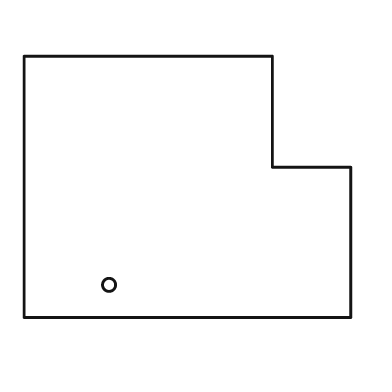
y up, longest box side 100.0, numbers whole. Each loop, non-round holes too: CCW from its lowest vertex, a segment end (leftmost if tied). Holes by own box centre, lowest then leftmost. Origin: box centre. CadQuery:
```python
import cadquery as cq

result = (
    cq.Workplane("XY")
    .moveTo(-50.0, -40.0)
    .lineTo(50.0, -40.0)
    .lineTo(50.0, 6.0)
    .lineTo(26.0, 6.0)
    .lineTo(26.0, 40.0)
    .lineTo(-50.0, 40.0)
    .close()
    .moveTo(-24.0, -30.0)
    .circle(2.0)
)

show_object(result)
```